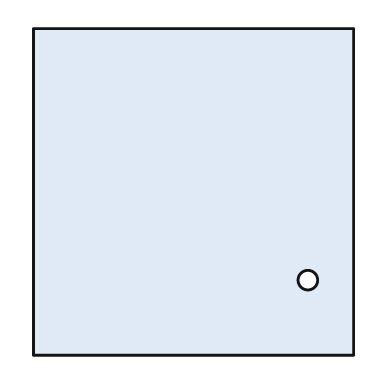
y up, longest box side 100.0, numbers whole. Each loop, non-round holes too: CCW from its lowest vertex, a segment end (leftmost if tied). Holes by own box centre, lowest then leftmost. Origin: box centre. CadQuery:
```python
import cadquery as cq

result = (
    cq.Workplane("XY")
    .moveTo(-49.0, -50.0)
    .lineTo(49.0, -50.0)
    .lineTo(49.0, 50.0)
    .lineTo(-49.0, 50.0)
    .close()
    .moveTo(35.0, -27.0)
    .circle(3.0)
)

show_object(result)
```